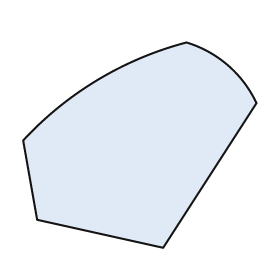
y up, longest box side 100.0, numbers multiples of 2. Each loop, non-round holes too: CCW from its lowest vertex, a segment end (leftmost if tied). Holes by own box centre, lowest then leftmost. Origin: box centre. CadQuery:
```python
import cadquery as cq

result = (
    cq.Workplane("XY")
    .moveTo(10.0, -44.0)
    .lineTo(50.0, 18.0)
    .threePointArc((38.0, 34.0), (20.0, 44.0))
    .threePointArc((-18.0, 28.0), (-50.0, 2.0))
    .lineTo(-44.0, -32.0)
    .close()
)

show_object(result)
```